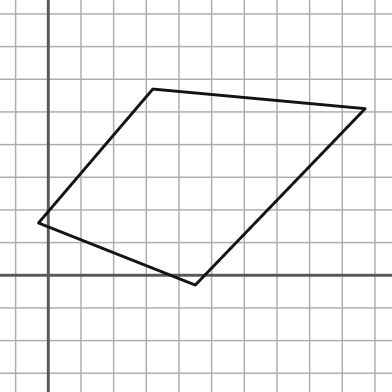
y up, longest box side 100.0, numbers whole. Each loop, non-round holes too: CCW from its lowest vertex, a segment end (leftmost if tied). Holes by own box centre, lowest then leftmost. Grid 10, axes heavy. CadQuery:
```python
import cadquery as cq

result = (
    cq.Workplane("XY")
    .moveTo(45.0, -3.0)
    .lineTo(97.0, 51.0)
    .lineTo(32.0, 57.0)
    .lineTo(-3.0, 16.0)
    .close()
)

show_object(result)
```